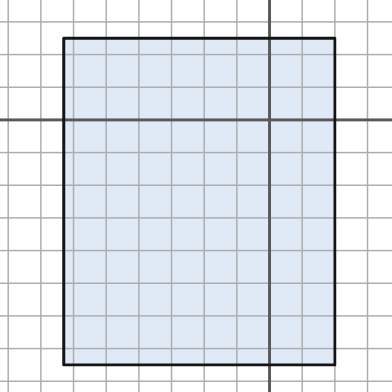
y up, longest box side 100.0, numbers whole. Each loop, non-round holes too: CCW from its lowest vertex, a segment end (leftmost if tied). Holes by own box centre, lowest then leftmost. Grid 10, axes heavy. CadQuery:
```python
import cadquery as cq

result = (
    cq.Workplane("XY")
    .moveTo(-63.0, -75.0)
    .lineTo(20.0, -75.0)
    .lineTo(20.0, 25.0)
    .lineTo(-63.0, 25.0)
    .close()
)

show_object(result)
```